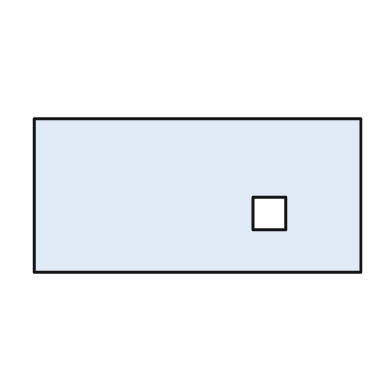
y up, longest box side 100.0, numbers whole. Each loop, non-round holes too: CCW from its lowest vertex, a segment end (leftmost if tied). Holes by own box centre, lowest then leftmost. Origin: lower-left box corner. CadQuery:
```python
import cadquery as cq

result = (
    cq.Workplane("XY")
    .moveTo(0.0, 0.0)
    .lineTo(100.0, 0.0)
    .lineTo(100.0, 47.0)
    .lineTo(0.0, 47.0)
    .close()
    .moveTo(67.0, 13.0)
    .lineTo(77.0, 13.0)
    .lineTo(77.0, 23.0)
    .lineTo(67.0, 23.0)
    .close()
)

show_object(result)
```